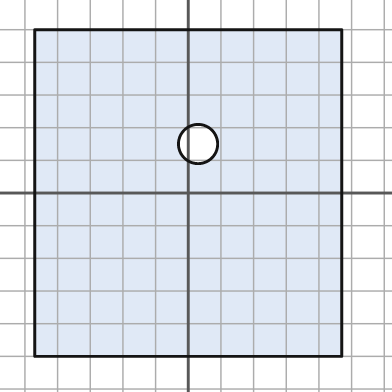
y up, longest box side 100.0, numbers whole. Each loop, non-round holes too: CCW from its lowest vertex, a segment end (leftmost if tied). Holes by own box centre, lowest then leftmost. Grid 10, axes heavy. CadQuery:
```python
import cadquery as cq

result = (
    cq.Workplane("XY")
    .moveTo(-47.0, -50.0)
    .lineTo(47.0, -50.0)
    .lineTo(47.0, 50.0)
    .lineTo(-47.0, 50.0)
    .close()
    .moveTo(3.0, 15.0)
    .circle(6.0)
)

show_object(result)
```